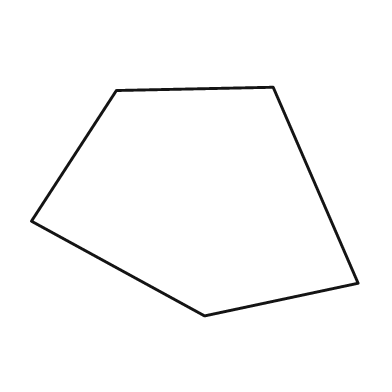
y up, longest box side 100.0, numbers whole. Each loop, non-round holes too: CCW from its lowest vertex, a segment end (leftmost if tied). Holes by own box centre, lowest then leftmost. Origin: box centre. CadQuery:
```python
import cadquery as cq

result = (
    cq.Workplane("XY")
    .moveTo(3.0, -35.0)
    .lineTo(50.0, -25.0)
    .lineTo(24.0, 35.0)
    .lineTo(-24.0, 34.0)
    .lineTo(-50.0, -6.0)
    .close()
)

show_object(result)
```